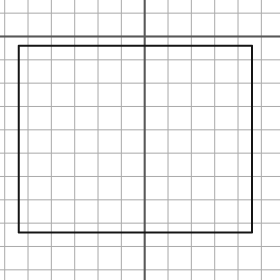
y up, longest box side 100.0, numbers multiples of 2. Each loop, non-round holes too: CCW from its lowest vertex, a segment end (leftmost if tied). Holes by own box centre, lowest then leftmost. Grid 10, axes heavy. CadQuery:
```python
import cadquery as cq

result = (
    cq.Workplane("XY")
    .moveTo(-54.0, -84.0)
    .lineTo(46.0, -84.0)
    .lineTo(46.0, -4.0)
    .lineTo(-54.0, -4.0)
    .close()
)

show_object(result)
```